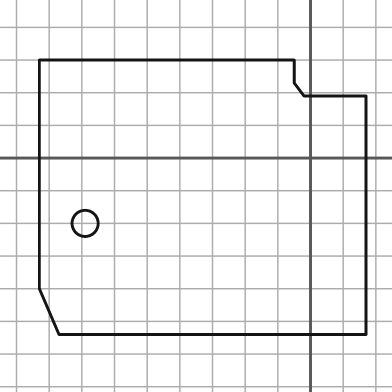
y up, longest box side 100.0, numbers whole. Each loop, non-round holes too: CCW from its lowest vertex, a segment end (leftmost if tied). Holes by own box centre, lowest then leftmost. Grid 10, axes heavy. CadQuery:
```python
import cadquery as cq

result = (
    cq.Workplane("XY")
    .moveTo(-77.0, -54.0)
    .lineTo(17.0, -54.0)
    .lineTo(17.0, 19.0)
    .lineTo(-2.0, 19.0)
    .lineTo(-5.0, 23.0)
    .lineTo(-5.0, 30.0)
    .lineTo(-83.0, 30.0)
    .lineTo(-83.0, -40.0)
    .close()
    .moveTo(-69.0, -20.0)
    .circle(4.0)
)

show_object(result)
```